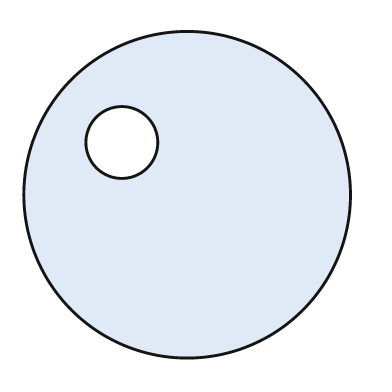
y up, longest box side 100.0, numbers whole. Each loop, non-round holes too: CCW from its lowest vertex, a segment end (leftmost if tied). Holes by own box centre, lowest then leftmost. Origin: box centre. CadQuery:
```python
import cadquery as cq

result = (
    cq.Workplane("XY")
    .moveTo(0.0, 0.0)
    .circle(50.0)
    .moveTo(-20.0, 16.0)
    .circle(11.0)
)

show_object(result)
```